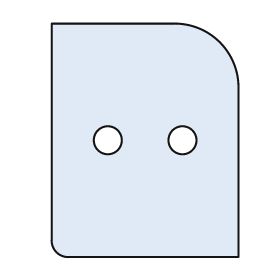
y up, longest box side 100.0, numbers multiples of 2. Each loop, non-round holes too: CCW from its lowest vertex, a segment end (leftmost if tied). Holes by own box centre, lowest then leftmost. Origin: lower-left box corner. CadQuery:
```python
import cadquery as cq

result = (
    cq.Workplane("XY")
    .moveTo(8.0, 0.0)
    .lineTo(80.0, 0.0)
    .lineTo(80.0, 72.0)
    .threePointArc((72.0, 92.0), (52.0, 100.0))
    .lineTo(0.0, 100.0)
    .lineTo(0.0, 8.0)
    .threePointArc((2.0, 2.0), (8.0, 0.0))
    .close()
    .moveTo(24.0, 50.0)
    .circle(6.0)
    .moveTo(56.0, 50.0)
    .circle(6.0)
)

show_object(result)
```